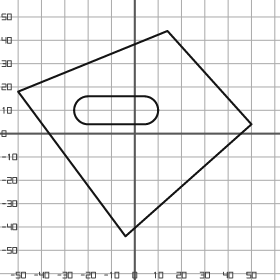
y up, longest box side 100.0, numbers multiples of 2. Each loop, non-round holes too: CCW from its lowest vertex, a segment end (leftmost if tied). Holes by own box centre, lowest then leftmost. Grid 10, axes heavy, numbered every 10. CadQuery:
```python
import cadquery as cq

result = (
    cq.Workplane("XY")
    .moveTo(-4.0, -44.0)
    .lineTo(50.0, 4.0)
    .lineTo(14.0, 44.0)
    .lineTo(-50.0, 18.0)
    .close()
    .moveTo(-20.0, 4.0)
    .lineTo(4.0, 4.0)
    .threePointArc((10.0, 10.0), (4.0, 16.0))
    .lineTo(-20.0, 16.0)
    .threePointArc((-26.0, 10.0), (-20.0, 4.0))
    .close()
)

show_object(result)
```